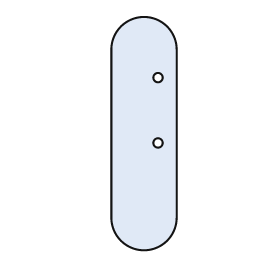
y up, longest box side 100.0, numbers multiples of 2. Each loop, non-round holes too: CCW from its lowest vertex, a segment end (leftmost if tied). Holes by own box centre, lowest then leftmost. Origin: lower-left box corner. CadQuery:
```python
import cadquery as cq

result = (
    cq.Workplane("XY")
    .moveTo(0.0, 14.0)
    .threePointArc((14.0, 0.0), (28.0, 14.0))
    .lineTo(28.0, 86.0)
    .threePointArc((14.0, 100.0), (0.0, 86.0))
    .close()
    .moveTo(20.0, 46.0)
    .circle(2.0)
    .moveTo(20.0, 74.0)
    .circle(2.0)
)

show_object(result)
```